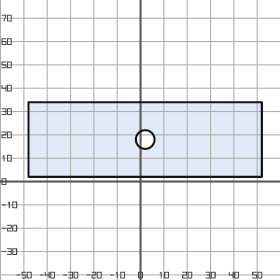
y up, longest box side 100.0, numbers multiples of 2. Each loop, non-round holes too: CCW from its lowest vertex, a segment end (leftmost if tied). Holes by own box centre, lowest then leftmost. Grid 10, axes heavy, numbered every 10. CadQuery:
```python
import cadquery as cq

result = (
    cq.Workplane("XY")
    .moveTo(-48.0, 2.0)
    .lineTo(52.0, 2.0)
    .lineTo(52.0, 34.0)
    .lineTo(-48.0, 34.0)
    .close()
    .moveTo(2.0, 18.0)
    .circle(4.0)
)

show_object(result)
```